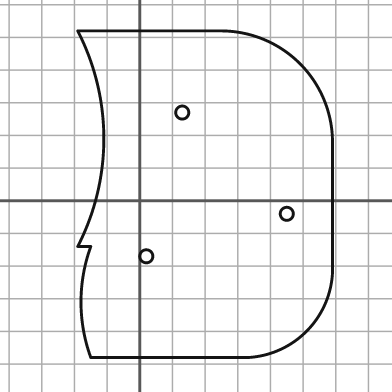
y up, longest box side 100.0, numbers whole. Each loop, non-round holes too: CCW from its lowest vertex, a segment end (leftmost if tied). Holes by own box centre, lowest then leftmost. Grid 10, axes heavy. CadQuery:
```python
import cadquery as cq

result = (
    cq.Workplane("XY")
    .moveTo(-15.0, -48.0)
    .lineTo(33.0, -48.0)
    .threePointArc((51.0, -40.0), (59.0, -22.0))
    .lineTo(59.0, 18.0)
    .threePointArc((49.0, 42.0), (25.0, 52.0))
    .lineTo(-19.0, 52.0)
    .threePointArc((-11.0, 19.0), (-19.0, -14.0))
    .lineTo(-15.0, -14.0)
    .threePointArc((-18.0, -31.0), (-15.0, -48.0))
    .close()
    .moveTo(2.0, -17.0)
    .circle(2.0)
    .moveTo(45.0, -4.0)
    .circle(2.0)
    .moveTo(13.0, 27.0)
    .circle(2.0)
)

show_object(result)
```